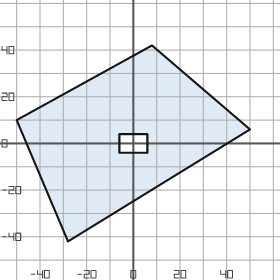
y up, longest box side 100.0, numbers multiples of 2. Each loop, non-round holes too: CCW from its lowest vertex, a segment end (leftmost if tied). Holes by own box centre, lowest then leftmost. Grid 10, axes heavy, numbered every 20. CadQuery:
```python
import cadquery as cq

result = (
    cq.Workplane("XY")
    .moveTo(-28.0, -42.0)
    .lineTo(50.0, 6.0)
    .lineTo(8.0, 42.0)
    .lineTo(-50.0, 10.0)
    .close()
    .moveTo(-6.0, -4.0)
    .lineTo(6.0, -4.0)
    .lineTo(6.0, 4.0)
    .lineTo(-6.0, 4.0)
    .close()
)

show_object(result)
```